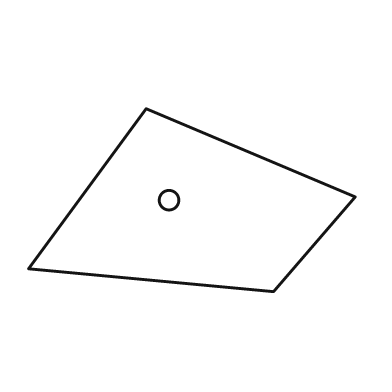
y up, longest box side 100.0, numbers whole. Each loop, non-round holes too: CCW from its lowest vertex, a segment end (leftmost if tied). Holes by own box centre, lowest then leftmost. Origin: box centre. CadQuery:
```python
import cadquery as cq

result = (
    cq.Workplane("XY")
    .moveTo(25.0, -28.0)
    .lineTo(50.0, 1.0)
    .lineTo(-14.0, 28.0)
    .lineTo(-50.0, -21.0)
    .close()
    .moveTo(-7.0, 0.0)
    .circle(3.0)
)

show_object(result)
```